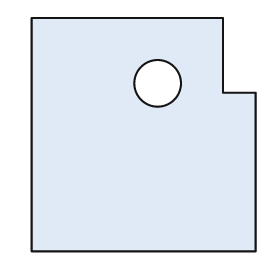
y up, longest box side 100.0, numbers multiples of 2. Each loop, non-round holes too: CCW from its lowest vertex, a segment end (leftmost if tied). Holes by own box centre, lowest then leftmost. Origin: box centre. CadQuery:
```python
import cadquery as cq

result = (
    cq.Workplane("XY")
    .moveTo(-48.0, -50.0)
    .lineTo(48.0, -50.0)
    .lineTo(48.0, 18.0)
    .lineTo(34.0, 18.0)
    .lineTo(34.0, 50.0)
    .lineTo(-48.0, 50.0)
    .close()
    .moveTo(6.0, 22.0)
    .circle(10.0)
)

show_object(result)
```